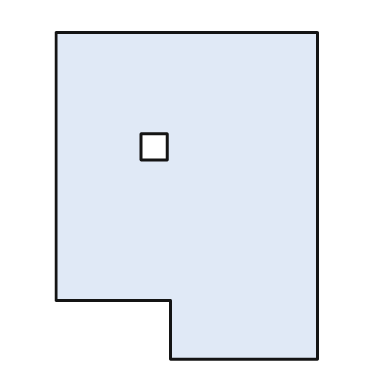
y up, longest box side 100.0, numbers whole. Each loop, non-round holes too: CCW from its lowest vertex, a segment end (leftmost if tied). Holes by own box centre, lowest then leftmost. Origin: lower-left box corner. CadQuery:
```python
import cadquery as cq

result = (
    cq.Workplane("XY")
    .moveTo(35.0, 0.0)
    .lineTo(80.0, 0.0)
    .lineTo(80.0, 100.0)
    .lineTo(0.0, 100.0)
    .lineTo(0.0, 18.0)
    .lineTo(35.0, 18.0)
    .close()
    .moveTo(26.0, 61.0)
    .lineTo(34.0, 61.0)
    .lineTo(34.0, 69.0)
    .lineTo(26.0, 69.0)
    .close()
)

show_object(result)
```